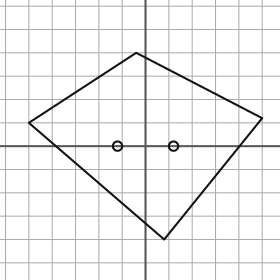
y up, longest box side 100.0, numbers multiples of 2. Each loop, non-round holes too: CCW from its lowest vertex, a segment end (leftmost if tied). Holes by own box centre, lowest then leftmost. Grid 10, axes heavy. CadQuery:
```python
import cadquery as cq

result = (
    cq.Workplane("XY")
    .moveTo(8.0, -40.0)
    .lineTo(50.0, 12.0)
    .lineTo(-4.0, 40.0)
    .lineTo(-50.0, 10.0)
    .close()
    .moveTo(-12.0, 0.0)
    .circle(2.0)
    .moveTo(12.0, 0.0)
    .circle(2.0)
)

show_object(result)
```